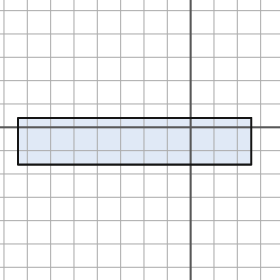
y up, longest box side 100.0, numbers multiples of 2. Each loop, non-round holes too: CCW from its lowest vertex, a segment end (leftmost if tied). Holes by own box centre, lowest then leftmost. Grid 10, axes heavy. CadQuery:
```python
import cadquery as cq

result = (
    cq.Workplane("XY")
    .moveTo(-74.0, -16.0)
    .lineTo(26.0, -16.0)
    .lineTo(26.0, 4.0)
    .lineTo(-74.0, 4.0)
    .close()
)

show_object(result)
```